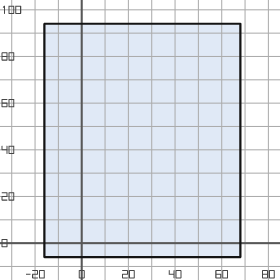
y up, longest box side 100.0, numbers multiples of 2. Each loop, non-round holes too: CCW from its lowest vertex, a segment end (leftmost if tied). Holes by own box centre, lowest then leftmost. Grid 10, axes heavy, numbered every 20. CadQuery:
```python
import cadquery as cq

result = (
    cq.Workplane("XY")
    .moveTo(-16.0, -6.0)
    .lineTo(68.0, -6.0)
    .lineTo(68.0, 94.0)
    .lineTo(-16.0, 94.0)
    .close()
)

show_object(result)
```